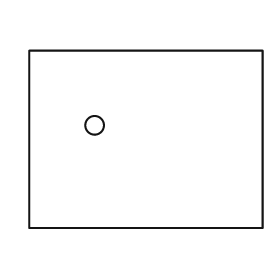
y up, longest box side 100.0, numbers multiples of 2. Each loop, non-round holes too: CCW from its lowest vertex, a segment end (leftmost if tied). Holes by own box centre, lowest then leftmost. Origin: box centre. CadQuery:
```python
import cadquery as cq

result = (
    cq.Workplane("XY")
    .moveTo(-50.0, -38.0)
    .lineTo(50.0, -38.0)
    .lineTo(50.0, 38.0)
    .lineTo(-50.0, 38.0)
    .close()
    .moveTo(-22.0, 6.0)
    .circle(4.0)
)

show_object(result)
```